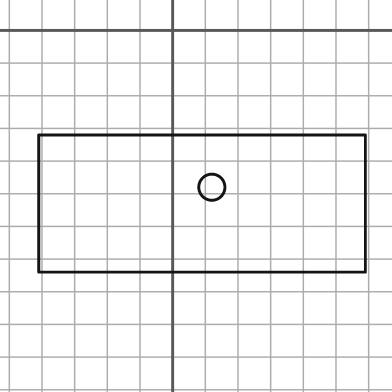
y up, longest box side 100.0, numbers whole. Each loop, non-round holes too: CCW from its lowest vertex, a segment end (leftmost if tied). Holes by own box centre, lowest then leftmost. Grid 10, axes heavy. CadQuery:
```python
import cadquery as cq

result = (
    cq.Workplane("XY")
    .moveTo(-41.0, -74.0)
    .lineTo(59.0, -74.0)
    .lineTo(59.0, -32.0)
    .lineTo(-41.0, -32.0)
    .close()
    .moveTo(12.0, -48.0)
    .circle(4.0)
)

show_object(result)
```